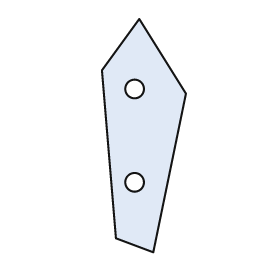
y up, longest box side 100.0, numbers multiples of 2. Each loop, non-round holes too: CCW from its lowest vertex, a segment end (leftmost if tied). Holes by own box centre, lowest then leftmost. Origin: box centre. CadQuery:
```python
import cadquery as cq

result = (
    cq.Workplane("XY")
    .moveTo(4.0, -50.0)
    .lineTo(18.0, 18.0)
    .lineTo(-2.0, 50.0)
    .lineTo(-18.0, 28.0)
    .lineTo(-12.0, -44.0)
    .close()
    .moveTo(-4.0, -20.0)
    .circle(4.0)
    .moveTo(-4.0, 20.0)
    .circle(4.0)
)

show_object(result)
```